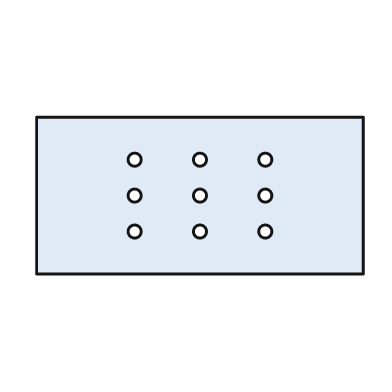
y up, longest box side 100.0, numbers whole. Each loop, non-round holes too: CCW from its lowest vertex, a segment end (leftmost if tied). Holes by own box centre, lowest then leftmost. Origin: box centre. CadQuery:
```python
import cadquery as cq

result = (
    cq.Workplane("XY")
    .moveTo(-50.0, -24.0)
    .lineTo(50.0, -24.0)
    .lineTo(50.0, 24.0)
    .lineTo(-50.0, 24.0)
    .close()
    .moveTo(-20.0, -11.0)
    .circle(2.0)
    .moveTo(0.0, -11.0)
    .circle(2.0)
    .moveTo(20.0, -11.0)
    .circle(2.0)
    .moveTo(-20.0, 0.0)
    .circle(2.0)
    .moveTo(0.0, 0.0)
    .circle(2.0)
    .moveTo(20.0, 0.0)
    .circle(2.0)
    .moveTo(-20.0, 11.0)
    .circle(2.0)
    .moveTo(0.0, 11.0)
    .circle(2.0)
    .moveTo(20.0, 11.0)
    .circle(2.0)
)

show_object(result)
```